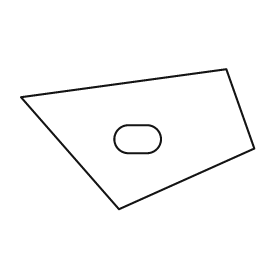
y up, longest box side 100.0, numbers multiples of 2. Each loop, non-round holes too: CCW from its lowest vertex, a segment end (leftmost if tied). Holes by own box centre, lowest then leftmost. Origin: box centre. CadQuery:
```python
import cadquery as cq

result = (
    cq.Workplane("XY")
    .moveTo(-8.0, -30.0)
    .lineTo(50.0, -4.0)
    .lineTo(38.0, 30.0)
    .lineTo(-50.0, 18.0)
    .close()
    .moveTo(-4.0, -6.0)
    .lineTo(4.0, -6.0)
    .threePointArc((10.0, 0.0), (4.0, 6.0))
    .lineTo(-4.0, 6.0)
    .threePointArc((-10.0, 0.0), (-4.0, -6.0))
    .close()
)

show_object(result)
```